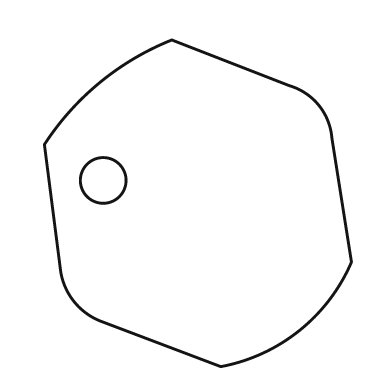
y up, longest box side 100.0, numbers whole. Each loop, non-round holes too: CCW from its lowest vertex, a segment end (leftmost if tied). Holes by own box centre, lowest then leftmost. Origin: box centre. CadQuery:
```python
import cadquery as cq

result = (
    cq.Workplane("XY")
    .moveTo(7.0, -50.0)
    .threePointArc((31.0, -39.0), (47.0, -18.0))
    .lineTo(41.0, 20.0)
    .threePointArc((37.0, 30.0), (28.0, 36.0))
    .lineTo(-8.0, 50.0)
    .threePointArc((-30.0, 37.0), (-47.0, 18.0))
    .lineTo(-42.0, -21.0)
    .threePointArc((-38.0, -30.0), (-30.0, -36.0))
    .close()
    .moveTo(-29.0, 7.0)
    .circle(7.0)
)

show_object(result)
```